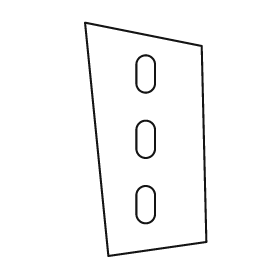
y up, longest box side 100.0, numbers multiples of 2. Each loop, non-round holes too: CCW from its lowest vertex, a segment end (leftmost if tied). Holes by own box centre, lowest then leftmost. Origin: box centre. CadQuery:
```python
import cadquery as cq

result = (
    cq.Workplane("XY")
    .moveTo(-16.0, -50.0)
    .lineTo(26.0, -44.0)
    .lineTo(24.0, 40.0)
    .lineTo(-26.0, 50.0)
    .close()
    .moveTo(-4.0, -32.0)
    .threePointArc((0.0, -36.0), (4.0, -32.0))
    .lineTo(4.0, -24.0)
    .threePointArc((0.0, -20.0), (-4.0, -24.0))
    .close()
    .moveTo(-4.0, -4.0)
    .threePointArc((0.0, -8.0), (4.0, -4.0))
    .lineTo(4.0, 4.0)
    .threePointArc((0.0, 8.0), (-4.0, 4.0))
    .close()
    .moveTo(-4.0, 24.0)
    .threePointArc((0.0, 20.0), (4.0, 24.0))
    .lineTo(4.0, 32.0)
    .threePointArc((0.0, 36.0), (-4.0, 32.0))
    .close()
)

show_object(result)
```